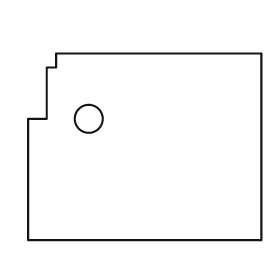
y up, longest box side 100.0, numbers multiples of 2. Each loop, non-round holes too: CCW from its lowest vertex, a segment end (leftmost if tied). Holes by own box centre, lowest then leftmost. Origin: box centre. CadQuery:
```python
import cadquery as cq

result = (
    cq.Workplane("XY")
    .moveTo(-50.0, -40.0)
    .lineTo(50.0, -40.0)
    .lineTo(50.0, 40.0)
    .lineTo(-38.0, 40.0)
    .lineTo(-38.0, 34.0)
    .lineTo(-42.0, 34.0)
    .lineTo(-42.0, 12.0)
    .lineTo(-50.0, 12.0)
    .close()
    .moveTo(-24.0, 12.0)
    .circle(6.0)
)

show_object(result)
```